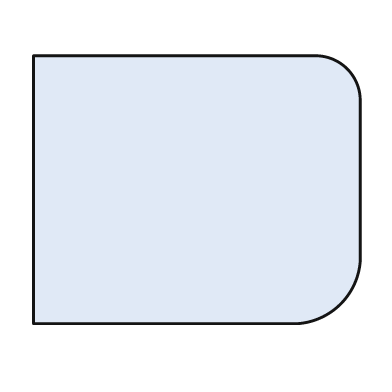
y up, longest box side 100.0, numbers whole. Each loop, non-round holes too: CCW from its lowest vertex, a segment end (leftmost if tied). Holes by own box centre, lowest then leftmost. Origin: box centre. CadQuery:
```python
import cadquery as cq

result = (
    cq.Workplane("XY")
    .moveTo(-50.0, -41.0)
    .lineTo(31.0, -41.0)
    .threePointArc((44.0, -35.0), (50.0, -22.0))
    .lineTo(50.0, 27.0)
    .threePointArc((46.0, 37.0), (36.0, 41.0))
    .lineTo(-50.0, 41.0)
    .close()
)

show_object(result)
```